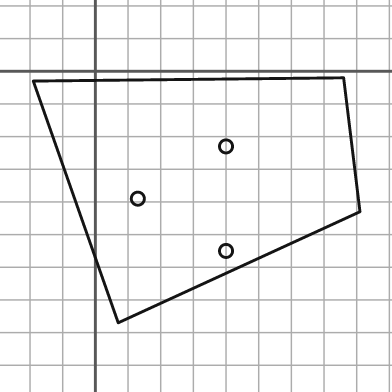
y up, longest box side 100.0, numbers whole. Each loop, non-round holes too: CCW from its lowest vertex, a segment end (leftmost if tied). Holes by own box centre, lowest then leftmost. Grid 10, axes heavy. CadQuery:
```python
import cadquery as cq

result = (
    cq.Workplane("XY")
    .moveTo(7.0, -77.0)
    .lineTo(81.0, -43.0)
    .lineTo(76.0, -2.0)
    .lineTo(-19.0, -3.0)
    .close()
    .moveTo(40.0, -55.0)
    .circle(2.0)
    .moveTo(13.0, -39.0)
    .circle(2.0)
    .moveTo(40.0, -23.0)
    .circle(2.0)
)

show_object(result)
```